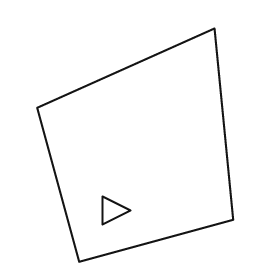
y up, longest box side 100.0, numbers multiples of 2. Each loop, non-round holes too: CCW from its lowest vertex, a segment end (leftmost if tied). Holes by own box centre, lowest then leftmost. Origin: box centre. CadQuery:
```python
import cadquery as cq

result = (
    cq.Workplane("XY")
    .moveTo(-24.0, -50.0)
    .lineTo(42.0, -32.0)
    .lineTo(34.0, 50.0)
    .lineTo(-42.0, 16.0)
    .close()
    .moveTo(-14.0, -34.0)
    .lineTo(-2.0, -28.0)
    .lineTo(-14.0, -22.0)
    .close()
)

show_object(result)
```